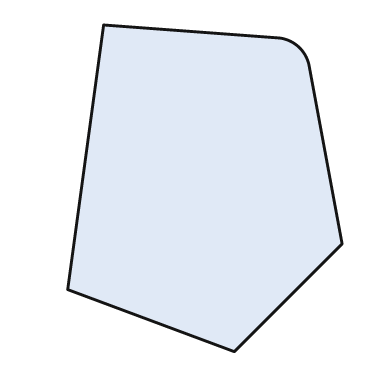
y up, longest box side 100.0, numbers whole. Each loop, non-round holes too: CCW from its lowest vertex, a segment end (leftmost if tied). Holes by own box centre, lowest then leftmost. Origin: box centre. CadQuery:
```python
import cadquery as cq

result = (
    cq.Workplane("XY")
    .moveTo(9.0, -50.0)
    .lineTo(42.0, -17.0)
    .lineTo(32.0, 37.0)
    .threePointArc((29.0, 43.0), (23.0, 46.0))
    .lineTo(-31.0, 50.0)
    .lineTo(-42.0, -31.0)
    .close()
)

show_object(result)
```